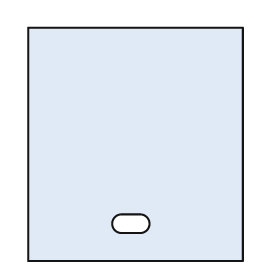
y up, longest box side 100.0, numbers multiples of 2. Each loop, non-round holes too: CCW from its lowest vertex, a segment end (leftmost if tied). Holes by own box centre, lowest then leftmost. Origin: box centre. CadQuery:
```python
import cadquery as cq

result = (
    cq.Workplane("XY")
    .moveTo(-46.0, -50.0)
    .lineTo(46.0, -50.0)
    .lineTo(46.0, 50.0)
    .lineTo(-46.0, 50.0)
    .close()
    .moveTo(-6.0, -38.0)
    .lineTo(2.0, -38.0)
    .threePointArc((6.0, -34.0), (2.0, -30.0))
    .lineTo(-6.0, -30.0)
    .threePointArc((-10.0, -34.0), (-6.0, -38.0))
    .close()
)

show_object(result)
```